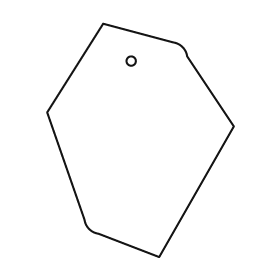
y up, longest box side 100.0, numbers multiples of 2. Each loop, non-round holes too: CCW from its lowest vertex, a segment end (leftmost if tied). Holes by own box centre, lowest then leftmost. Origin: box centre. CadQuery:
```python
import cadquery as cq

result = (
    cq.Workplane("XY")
    .moveTo(8.0, -50.0)
    .lineTo(40.0, 6.0)
    .lineTo(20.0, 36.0)
    .threePointArc((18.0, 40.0), (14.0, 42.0))
    .lineTo(-16.0, 50.0)
    .lineTo(-40.0, 12.0)
    .lineTo(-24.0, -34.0)
    .threePointArc((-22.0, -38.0), (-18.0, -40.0))
    .close()
    .moveTo(-4.0, 34.0)
    .circle(2.0)
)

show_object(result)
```